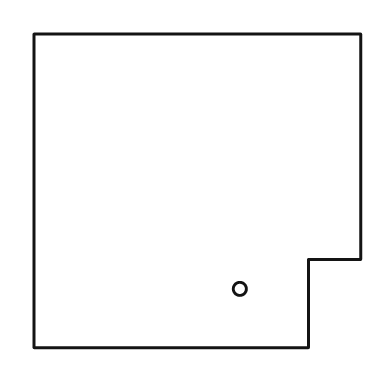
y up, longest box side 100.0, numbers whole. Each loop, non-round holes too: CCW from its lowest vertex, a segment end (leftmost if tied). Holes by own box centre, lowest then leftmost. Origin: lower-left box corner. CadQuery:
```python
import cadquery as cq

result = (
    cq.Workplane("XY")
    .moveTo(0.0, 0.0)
    .lineTo(84.0, 0.0)
    .lineTo(84.0, 27.0)
    .lineTo(100.0, 27.0)
    .lineTo(100.0, 96.0)
    .lineTo(0.0, 96.0)
    .close()
    .moveTo(63.0, 18.0)
    .circle(2.0)
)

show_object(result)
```